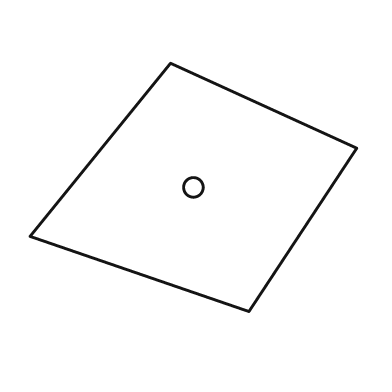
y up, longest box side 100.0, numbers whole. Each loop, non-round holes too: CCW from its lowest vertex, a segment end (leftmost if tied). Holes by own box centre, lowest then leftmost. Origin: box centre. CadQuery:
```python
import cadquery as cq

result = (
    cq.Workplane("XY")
    .moveTo(17.0, -38.0)
    .lineTo(50.0, 12.0)
    .lineTo(-7.0, 38.0)
    .lineTo(-50.0, -15.0)
    .close()
    .moveTo(0.0, 0.0)
    .circle(3.0)
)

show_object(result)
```